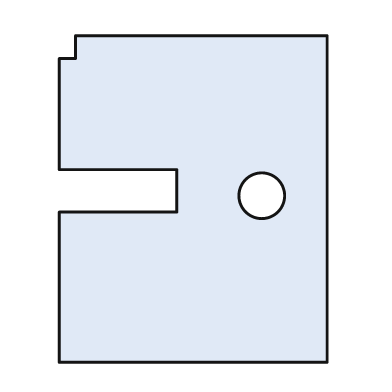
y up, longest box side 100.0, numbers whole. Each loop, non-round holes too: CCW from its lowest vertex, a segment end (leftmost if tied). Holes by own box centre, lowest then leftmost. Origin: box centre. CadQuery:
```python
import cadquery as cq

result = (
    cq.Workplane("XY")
    .moveTo(-41.0, -50.0)
    .lineTo(41.0, -50.0)
    .lineTo(41.0, 50.0)
    .lineTo(-36.0, 50.0)
    .lineTo(-36.0, 43.0)
    .lineTo(-41.0, 43.0)
    .lineTo(-41.0, 9.0)
    .lineTo(-5.0, 9.0)
    .lineTo(-5.0, -4.0)
    .lineTo(-41.0, -4.0)
    .close()
    .moveTo(21.0, 1.0)
    .circle(7.0)
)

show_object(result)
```